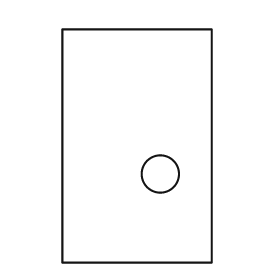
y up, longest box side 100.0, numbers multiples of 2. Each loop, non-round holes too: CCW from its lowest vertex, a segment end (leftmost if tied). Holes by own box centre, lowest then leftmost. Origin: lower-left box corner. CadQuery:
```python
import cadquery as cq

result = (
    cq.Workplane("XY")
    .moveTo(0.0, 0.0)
    .lineTo(64.0, 0.0)
    .lineTo(64.0, 100.0)
    .lineTo(0.0, 100.0)
    .close()
    .moveTo(42.0, 38.0)
    .circle(8.0)
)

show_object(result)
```